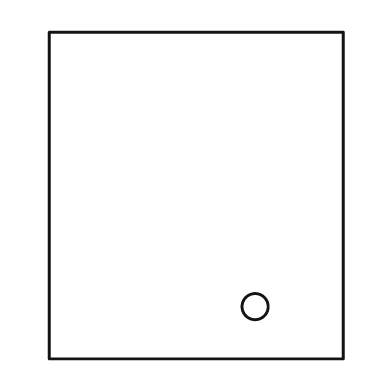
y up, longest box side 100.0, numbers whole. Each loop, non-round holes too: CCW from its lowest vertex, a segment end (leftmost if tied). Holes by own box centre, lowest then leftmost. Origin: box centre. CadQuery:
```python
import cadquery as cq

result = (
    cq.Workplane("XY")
    .moveTo(-45.0, -50.0)
    .lineTo(45.0, -50.0)
    .lineTo(45.0, 50.0)
    .lineTo(-45.0, 50.0)
    .close()
    .moveTo(18.0, -34.0)
    .circle(4.0)
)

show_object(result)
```